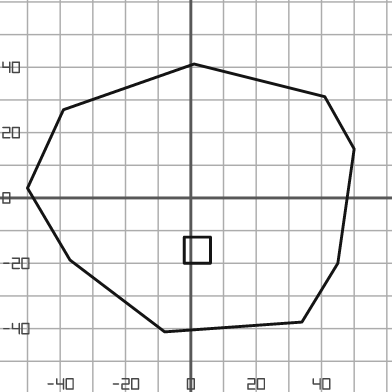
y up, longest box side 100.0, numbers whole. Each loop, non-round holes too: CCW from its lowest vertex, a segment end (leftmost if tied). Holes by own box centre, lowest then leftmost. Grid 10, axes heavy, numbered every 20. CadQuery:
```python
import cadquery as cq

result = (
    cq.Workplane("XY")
    .moveTo(-8.0, -41.0)
    .lineTo(34.0, -38.0)
    .lineTo(45.0, -20.0)
    .lineTo(50.0, 15.0)
    .lineTo(41.0, 31.0)
    .lineTo(1.0, 41.0)
    .lineTo(-39.0, 27.0)
    .lineTo(-50.0, 3.0)
    .lineTo(-37.0, -19.0)
    .close()
    .moveTo(-2.0, -20.0)
    .lineTo(6.0, -20.0)
    .lineTo(6.0, -12.0)
    .lineTo(-2.0, -12.0)
    .close()
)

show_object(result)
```